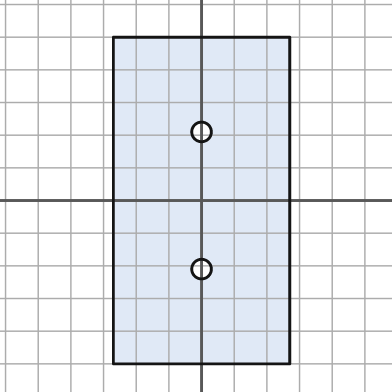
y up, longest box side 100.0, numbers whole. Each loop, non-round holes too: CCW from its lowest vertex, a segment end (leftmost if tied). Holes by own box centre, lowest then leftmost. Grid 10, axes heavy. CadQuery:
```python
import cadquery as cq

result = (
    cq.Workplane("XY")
    .moveTo(-27.0, -50.0)
    .lineTo(27.0, -50.0)
    .lineTo(27.0, 50.0)
    .lineTo(-27.0, 50.0)
    .close()
    .moveTo(0.0, -21.0)
    .circle(3.0)
    .moveTo(0.0, 21.0)
    .circle(3.0)
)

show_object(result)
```